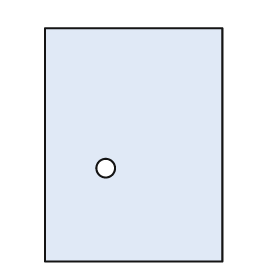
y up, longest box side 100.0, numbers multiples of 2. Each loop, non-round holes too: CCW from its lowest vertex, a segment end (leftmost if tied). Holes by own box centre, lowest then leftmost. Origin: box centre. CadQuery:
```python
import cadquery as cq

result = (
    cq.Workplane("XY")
    .moveTo(-38.0, -50.0)
    .lineTo(38.0, -50.0)
    .lineTo(38.0, 50.0)
    .lineTo(-38.0, 50.0)
    .close()
    .moveTo(-12.0, -10.0)
    .circle(4.0)
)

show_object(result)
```